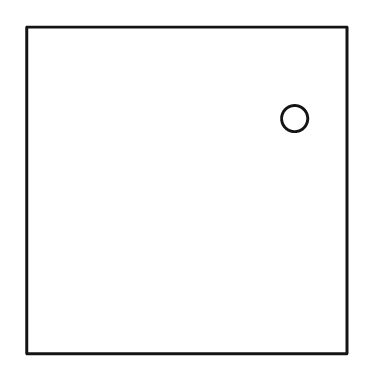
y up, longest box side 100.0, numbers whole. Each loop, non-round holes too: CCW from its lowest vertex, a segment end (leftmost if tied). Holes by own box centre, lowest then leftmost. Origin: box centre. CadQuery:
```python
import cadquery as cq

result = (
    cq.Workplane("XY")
    .moveTo(-49.0, -50.0)
    .lineTo(49.0, -50.0)
    .lineTo(49.0, 50.0)
    .lineTo(-49.0, 50.0)
    .close()
    .moveTo(33.0, 22.0)
    .circle(4.0)
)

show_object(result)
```